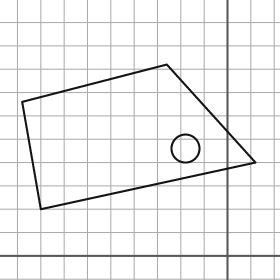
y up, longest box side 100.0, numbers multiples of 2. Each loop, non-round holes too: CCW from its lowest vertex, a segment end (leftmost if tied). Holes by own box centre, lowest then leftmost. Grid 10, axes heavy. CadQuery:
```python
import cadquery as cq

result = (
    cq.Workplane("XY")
    .moveTo(-80.0, 20.0)
    .lineTo(12.0, 40.0)
    .lineTo(-26.0, 82.0)
    .lineTo(-88.0, 66.0)
    .close()
    .moveTo(-18.0, 46.0)
    .circle(6.0)
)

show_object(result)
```